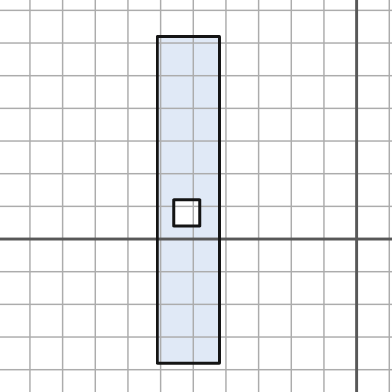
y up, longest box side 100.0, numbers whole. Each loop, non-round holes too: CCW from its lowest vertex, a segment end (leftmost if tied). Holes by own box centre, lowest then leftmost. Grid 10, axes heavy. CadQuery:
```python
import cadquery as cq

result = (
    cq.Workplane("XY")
    .moveTo(-61.0, -38.0)
    .lineTo(-42.0, -38.0)
    .lineTo(-42.0, 62.0)
    .lineTo(-61.0, 62.0)
    .close()
    .moveTo(-56.0, 4.0)
    .lineTo(-48.0, 4.0)
    .lineTo(-48.0, 12.0)
    .lineTo(-56.0, 12.0)
    .close()
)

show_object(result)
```